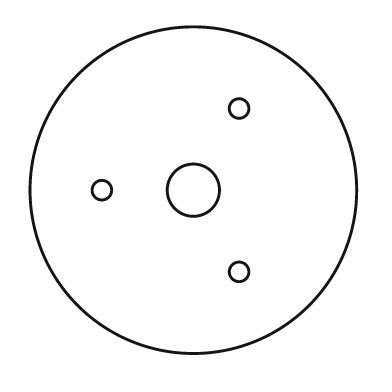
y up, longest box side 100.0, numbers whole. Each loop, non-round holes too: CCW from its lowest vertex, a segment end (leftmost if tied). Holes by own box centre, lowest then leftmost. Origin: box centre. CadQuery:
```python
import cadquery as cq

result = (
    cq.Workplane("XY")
    .moveTo(0.0, 0.0)
    .circle(50.0)
    .moveTo(14.0, -25.0)
    .circle(3.0)
    .moveTo(-28.0, 0.0)
    .circle(3.0)
    .moveTo(0.0, 0.0)
    .circle(8.0)
    .moveTo(14.0, 25.0)
    .circle(3.0)
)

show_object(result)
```